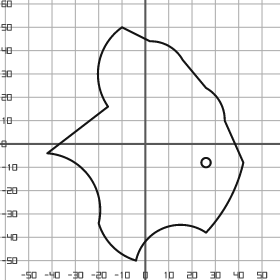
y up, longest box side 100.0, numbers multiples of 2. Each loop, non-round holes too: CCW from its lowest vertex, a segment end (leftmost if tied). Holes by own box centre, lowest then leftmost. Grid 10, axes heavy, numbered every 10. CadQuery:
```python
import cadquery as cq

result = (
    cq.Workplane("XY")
    .moveTo(-4.0, -50.0)
    .threePointArc((8.0, -36.0), (26.0, -38.0))
    .threePointArc((36.0, -24.0), (42.0, -8.0))
    .lineTo(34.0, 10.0)
    .threePointArc((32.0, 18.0), (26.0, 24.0))
    .lineTo(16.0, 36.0)
    .threePointArc((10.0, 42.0), (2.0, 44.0))
    .lineTo(-10.0, 50.0)
    .threePointArc((-20.0, 34.0), (-16.0, 16.0))
    .lineTo(-42.0, -4.0)
    .threePointArc((-24.0, -14.0), (-20.0, -34.0))
    .threePointArc((-14.0, -44.0), (-4.0, -50.0))
    .close()
    .moveTo(26.0, -8.0)
    .circle(2.0)
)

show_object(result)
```